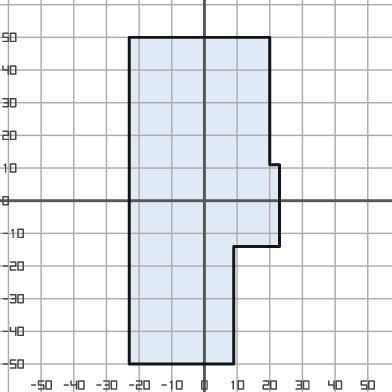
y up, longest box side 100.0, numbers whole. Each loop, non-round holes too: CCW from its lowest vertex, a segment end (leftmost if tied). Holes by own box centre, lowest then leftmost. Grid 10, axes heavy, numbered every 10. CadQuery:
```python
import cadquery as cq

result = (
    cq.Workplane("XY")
    .moveTo(-23.0, -50.0)
    .lineTo(9.0, -50.0)
    .lineTo(9.0, -14.0)
    .lineTo(23.0, -14.0)
    .lineTo(23.0, 11.0)
    .lineTo(20.0, 11.0)
    .lineTo(20.0, 50.0)
    .lineTo(-23.0, 50.0)
    .close()
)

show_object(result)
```